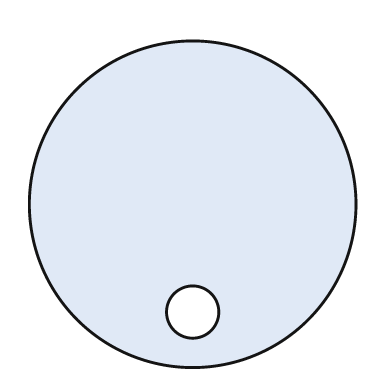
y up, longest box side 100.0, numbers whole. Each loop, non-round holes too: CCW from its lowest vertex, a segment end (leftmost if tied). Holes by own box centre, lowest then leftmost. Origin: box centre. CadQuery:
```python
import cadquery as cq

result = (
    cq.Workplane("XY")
    .moveTo(0.0, 0.0)
    .circle(50.0)
    .moveTo(0.0, -33.0)
    .circle(8.0)
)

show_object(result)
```